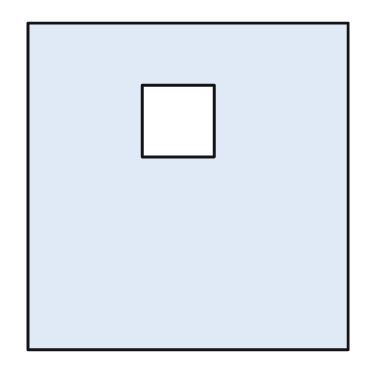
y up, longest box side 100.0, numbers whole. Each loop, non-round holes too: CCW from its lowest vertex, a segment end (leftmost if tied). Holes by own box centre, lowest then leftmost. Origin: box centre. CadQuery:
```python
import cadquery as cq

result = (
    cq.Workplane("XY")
    .moveTo(-49.0, -50.0)
    .lineTo(49.0, -50.0)
    .lineTo(49.0, 50.0)
    .lineTo(-49.0, 50.0)
    .close()
    .moveTo(-14.0, 9.0)
    .lineTo(8.0, 9.0)
    .lineTo(8.0, 31.0)
    .lineTo(-14.0, 31.0)
    .close()
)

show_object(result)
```